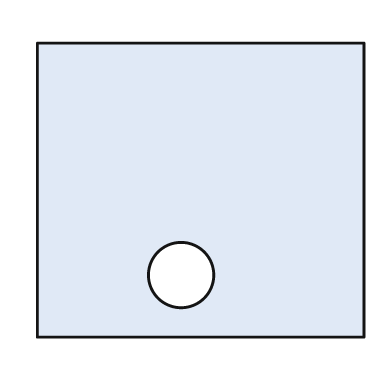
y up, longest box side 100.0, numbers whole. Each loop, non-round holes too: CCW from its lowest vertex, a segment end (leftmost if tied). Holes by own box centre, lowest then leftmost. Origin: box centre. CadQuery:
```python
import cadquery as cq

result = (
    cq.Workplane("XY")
    .moveTo(-50.0, -45.0)
    .lineTo(50.0, -45.0)
    .lineTo(50.0, 45.0)
    .lineTo(-50.0, 45.0)
    .close()
    .moveTo(-6.0, -26.0)
    .circle(10.0)
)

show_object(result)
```